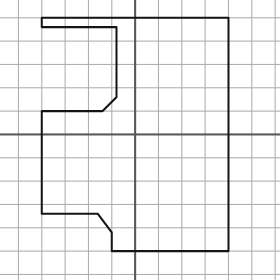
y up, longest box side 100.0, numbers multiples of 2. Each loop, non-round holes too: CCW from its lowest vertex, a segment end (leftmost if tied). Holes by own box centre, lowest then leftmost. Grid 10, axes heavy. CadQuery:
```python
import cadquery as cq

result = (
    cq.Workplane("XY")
    .moveTo(-10.0, -50.0)
    .lineTo(40.0, -50.0)
    .lineTo(40.0, 50.0)
    .lineTo(-40.0, 50.0)
    .lineTo(-40.0, 46.0)
    .lineTo(-8.0, 46.0)
    .lineTo(-8.0, 16.0)
    .lineTo(-14.0, 10.0)
    .lineTo(-40.0, 10.0)
    .lineTo(-40.0, -34.0)
    .lineTo(-16.0, -34.0)
    .lineTo(-10.0, -42.0)
    .close()
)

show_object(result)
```